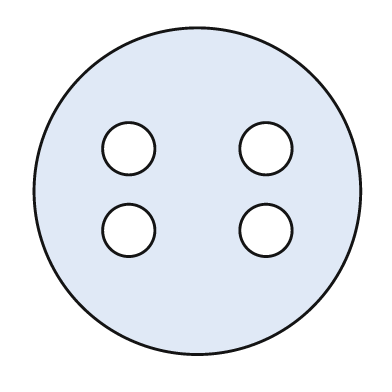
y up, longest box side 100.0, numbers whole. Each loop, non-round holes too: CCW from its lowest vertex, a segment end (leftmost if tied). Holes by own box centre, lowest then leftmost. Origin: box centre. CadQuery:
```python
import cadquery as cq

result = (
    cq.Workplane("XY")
    .moveTo(0.0, 0.0)
    .circle(50.0)
    .moveTo(-21.0, -12.0)
    .circle(8.0)
    .moveTo(21.0, -12.0)
    .circle(8.0)
    .moveTo(-21.0, 13.0)
    .circle(8.0)
    .moveTo(21.0, 13.0)
    .circle(8.0)
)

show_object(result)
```